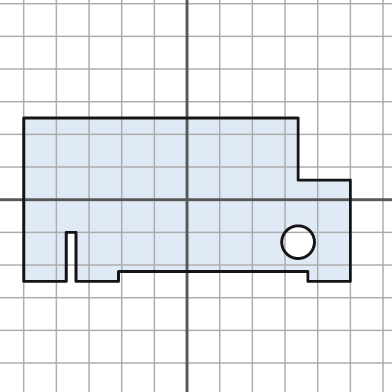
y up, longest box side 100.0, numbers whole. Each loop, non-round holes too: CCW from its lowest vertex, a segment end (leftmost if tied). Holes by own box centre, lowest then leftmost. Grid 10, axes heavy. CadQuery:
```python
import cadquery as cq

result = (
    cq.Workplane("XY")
    .moveTo(-50.0, -25.0)
    .lineTo(-37.0, -25.0)
    .lineTo(-37.0, -10.0)
    .lineTo(-34.0, -10.0)
    .lineTo(-34.0, -25.0)
    .lineTo(-21.0, -25.0)
    .lineTo(-21.0, -22.0)
    .lineTo(37.0, -22.0)
    .lineTo(37.0, -25.0)
    .lineTo(50.0, -25.0)
    .lineTo(50.0, 6.0)
    .lineTo(34.0, 6.0)
    .lineTo(34.0, 25.0)
    .lineTo(-50.0, 25.0)
    .close()
    .moveTo(34.0, -13.0)
    .circle(5.0)
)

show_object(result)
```